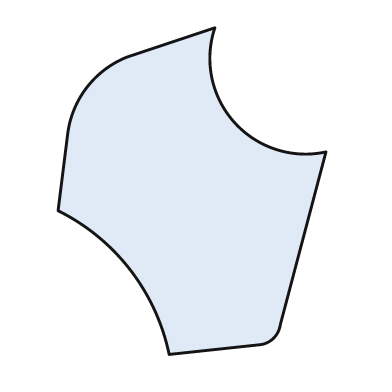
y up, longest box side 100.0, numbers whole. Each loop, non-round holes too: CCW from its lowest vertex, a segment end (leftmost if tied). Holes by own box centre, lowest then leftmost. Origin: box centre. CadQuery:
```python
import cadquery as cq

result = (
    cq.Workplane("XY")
    .moveTo(-7.0, -50.0)
    .lineTo(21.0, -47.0)
    .threePointArc((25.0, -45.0), (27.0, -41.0))
    .lineTo(41.0, 12.0)
    .threePointArc((13.0, 21.0), (7.0, 50.0))
    .lineTo(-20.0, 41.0)
    .threePointArc((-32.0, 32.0), (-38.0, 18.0))
    .lineTo(-41.0, -6.0)
    .threePointArc((-19.0, -24.0), (-7.0, -50.0))
    .close()
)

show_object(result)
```